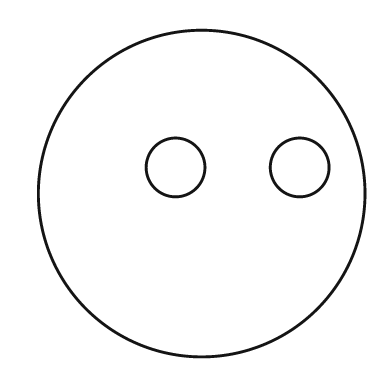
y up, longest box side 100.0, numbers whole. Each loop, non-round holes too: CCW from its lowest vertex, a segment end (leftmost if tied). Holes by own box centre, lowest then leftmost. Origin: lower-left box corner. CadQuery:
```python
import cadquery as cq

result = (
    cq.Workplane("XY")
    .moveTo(50.0, 50.0)
    .circle(50.0)
    .moveTo(42.0, 58.0)
    .circle(9.0)
    .moveTo(80.0, 58.0)
    .circle(9.0)
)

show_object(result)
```